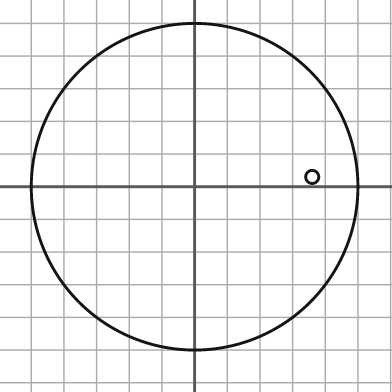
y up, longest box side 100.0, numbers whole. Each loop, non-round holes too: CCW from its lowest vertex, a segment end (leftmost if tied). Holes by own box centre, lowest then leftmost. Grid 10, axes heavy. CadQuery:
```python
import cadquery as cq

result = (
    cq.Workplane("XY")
    .moveTo(0.0, 0.0)
    .circle(50.0)
    .moveTo(36.0, 3.0)
    .circle(2.0)
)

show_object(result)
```